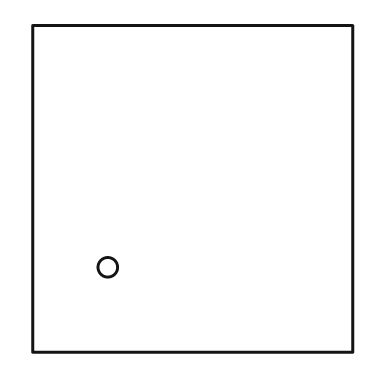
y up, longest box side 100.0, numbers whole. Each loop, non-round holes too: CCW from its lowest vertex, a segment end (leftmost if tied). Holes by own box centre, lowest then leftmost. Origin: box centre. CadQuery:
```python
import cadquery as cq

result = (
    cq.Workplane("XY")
    .moveTo(-49.0, -50.0)
    .lineTo(49.0, -50.0)
    .lineTo(49.0, 50.0)
    .lineTo(-49.0, 50.0)
    .close()
    .moveTo(-26.0, -24.0)
    .circle(3.0)
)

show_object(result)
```